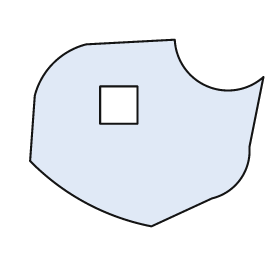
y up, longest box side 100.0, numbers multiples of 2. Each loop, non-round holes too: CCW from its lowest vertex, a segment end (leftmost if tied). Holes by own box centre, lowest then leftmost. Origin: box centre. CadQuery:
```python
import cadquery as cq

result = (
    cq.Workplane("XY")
    .moveTo(2.0, -40.0)
    .lineTo(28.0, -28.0)
    .threePointArc((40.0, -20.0), (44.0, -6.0))
    .lineTo(50.0, 24.0)
    .threePointArc((26.0, 20.0), (12.0, 40.0))
    .lineTo(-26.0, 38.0)
    .threePointArc((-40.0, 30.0), (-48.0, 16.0))
    .lineTo(-50.0, -12.0)
    .threePointArc((-26.0, -30.0), (2.0, -40.0))
    .close()
    .moveTo(-20.0, 4.0)
    .lineTo(-4.0, 4.0)
    .lineTo(-4.0, 20.0)
    .lineTo(-20.0, 20.0)
    .close()
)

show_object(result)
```